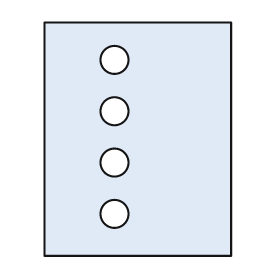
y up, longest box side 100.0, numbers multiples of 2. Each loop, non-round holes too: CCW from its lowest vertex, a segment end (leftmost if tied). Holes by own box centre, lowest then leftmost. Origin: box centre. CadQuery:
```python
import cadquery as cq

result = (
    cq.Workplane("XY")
    .moveTo(-40.0, -50.0)
    .lineTo(40.0, -50.0)
    .lineTo(40.0, 50.0)
    .lineTo(-40.0, 50.0)
    .close()
    .moveTo(-10.0, -32.0)
    .circle(6.0)
    .moveTo(-10.0, -10.0)
    .circle(6.0)
    .moveTo(-10.0, 12.0)
    .circle(6.0)
    .moveTo(-10.0, 34.0)
    .circle(6.0)
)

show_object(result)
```